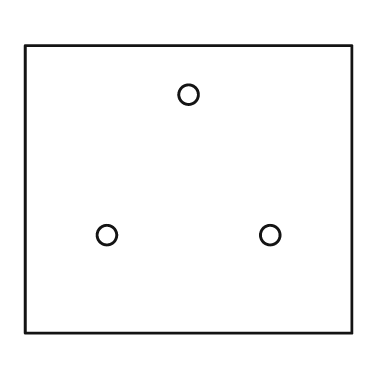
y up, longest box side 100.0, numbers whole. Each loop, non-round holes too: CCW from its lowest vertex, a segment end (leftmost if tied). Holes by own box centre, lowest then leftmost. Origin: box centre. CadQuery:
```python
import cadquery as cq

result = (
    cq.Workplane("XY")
    .moveTo(-50.0, -44.0)
    .lineTo(50.0, -44.0)
    .lineTo(50.0, 44.0)
    .lineTo(-50.0, 44.0)
    .close()
    .moveTo(-25.0, -14.0)
    .circle(3.0)
    .moveTo(25.0, -14.0)
    .circle(3.0)
    .moveTo(0.0, 29.0)
    .circle(3.0)
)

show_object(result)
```